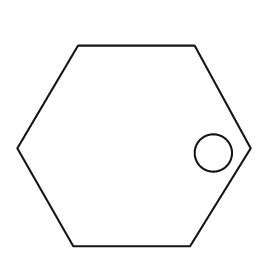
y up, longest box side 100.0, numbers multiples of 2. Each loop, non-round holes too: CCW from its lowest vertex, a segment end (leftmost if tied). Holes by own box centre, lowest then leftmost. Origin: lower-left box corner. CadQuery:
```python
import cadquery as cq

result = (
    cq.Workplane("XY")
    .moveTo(24.0, 0.0)
    .lineTo(74.0, 0.0)
    .lineTo(100.0, 42.0)
    .lineTo(76.0, 86.0)
    .lineTo(26.0, 86.0)
    .lineTo(0.0, 42.0)
    .close()
    .moveTo(84.0, 40.0)
    .circle(8.0)
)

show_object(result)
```